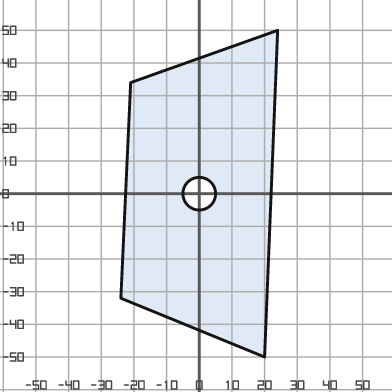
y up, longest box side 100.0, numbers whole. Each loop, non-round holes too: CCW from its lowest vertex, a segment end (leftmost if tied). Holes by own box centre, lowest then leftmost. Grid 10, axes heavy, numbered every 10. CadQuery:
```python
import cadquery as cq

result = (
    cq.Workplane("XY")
    .moveTo(20.0, -50.0)
    .lineTo(24.0, 50.0)
    .lineTo(-21.0, 34.0)
    .lineTo(-24.0, -32.0)
    .close()
    .moveTo(0.0, 0.0)
    .circle(5.0)
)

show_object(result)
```